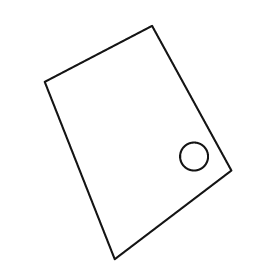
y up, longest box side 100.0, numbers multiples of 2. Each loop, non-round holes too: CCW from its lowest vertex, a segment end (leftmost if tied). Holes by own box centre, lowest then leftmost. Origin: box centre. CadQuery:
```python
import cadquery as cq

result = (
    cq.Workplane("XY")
    .moveTo(-10.0, -50.0)
    .lineTo(40.0, -12.0)
    .lineTo(6.0, 50.0)
    .lineTo(-40.0, 26.0)
    .close()
    .moveTo(24.0, -6.0)
    .circle(6.0)
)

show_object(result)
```